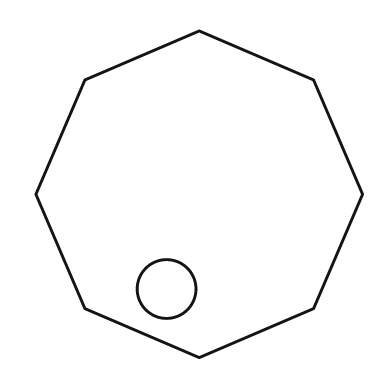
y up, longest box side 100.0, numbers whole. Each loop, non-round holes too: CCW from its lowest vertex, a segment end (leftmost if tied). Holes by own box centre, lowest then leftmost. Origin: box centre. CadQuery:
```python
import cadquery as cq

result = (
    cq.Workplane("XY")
    .moveTo(0.0, -50.0)
    .lineTo(35.0, -35.0)
    .lineTo(50.0, 0.0)
    .lineTo(35.0, 35.0)
    .lineTo(0.0, 50.0)
    .lineTo(-35.0, 35.0)
    .lineTo(-50.0, 0.0)
    .lineTo(-35.0, -35.0)
    .close()
    .moveTo(-10.0, -29.0)
    .circle(9.0)
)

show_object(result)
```